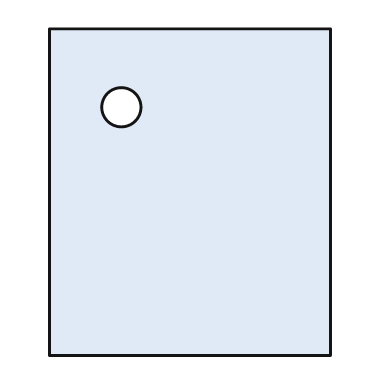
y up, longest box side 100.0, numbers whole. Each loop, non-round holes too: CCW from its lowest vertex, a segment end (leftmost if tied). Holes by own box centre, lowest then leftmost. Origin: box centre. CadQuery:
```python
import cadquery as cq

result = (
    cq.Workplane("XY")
    .moveTo(-43.0, -50.0)
    .lineTo(43.0, -50.0)
    .lineTo(43.0, 50.0)
    .lineTo(-43.0, 50.0)
    .close()
    .moveTo(-21.0, 26.0)
    .circle(6.0)
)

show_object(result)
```